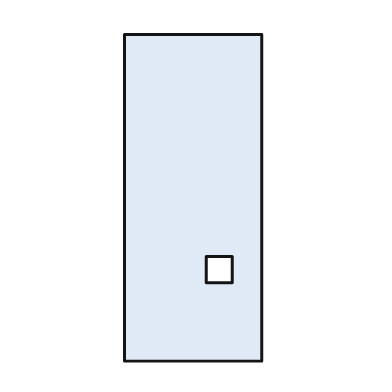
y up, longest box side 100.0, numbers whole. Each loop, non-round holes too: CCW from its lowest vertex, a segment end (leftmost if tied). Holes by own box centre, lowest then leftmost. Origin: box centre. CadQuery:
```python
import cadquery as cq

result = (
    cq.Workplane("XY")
    .moveTo(-21.0, -50.0)
    .lineTo(21.0, -50.0)
    .lineTo(21.0, 50.0)
    .lineTo(-21.0, 50.0)
    .close()
    .moveTo(4.0, -26.0)
    .lineTo(12.0, -26.0)
    .lineTo(12.0, -18.0)
    .lineTo(4.0, -18.0)
    .close()
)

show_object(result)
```